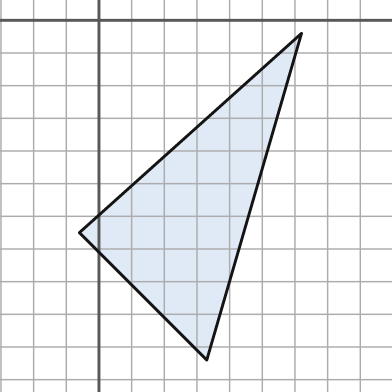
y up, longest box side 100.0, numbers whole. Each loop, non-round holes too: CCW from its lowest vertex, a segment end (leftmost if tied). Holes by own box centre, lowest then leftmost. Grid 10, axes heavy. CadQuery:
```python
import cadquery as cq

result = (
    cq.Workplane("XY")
    .moveTo(33.0, -104.0)
    .lineTo(62.0, -4.0)
    .lineTo(-6.0, -65.0)
    .close()
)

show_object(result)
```